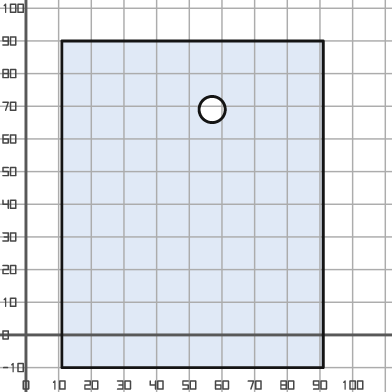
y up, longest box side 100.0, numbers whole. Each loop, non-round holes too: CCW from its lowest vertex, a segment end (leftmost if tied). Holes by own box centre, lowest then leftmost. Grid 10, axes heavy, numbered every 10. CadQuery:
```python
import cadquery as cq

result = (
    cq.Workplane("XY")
    .moveTo(11.0, -10.0)
    .lineTo(91.0, -10.0)
    .lineTo(91.0, 90.0)
    .lineTo(11.0, 90.0)
    .close()
    .moveTo(57.0, 69.0)
    .circle(4.0)
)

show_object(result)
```